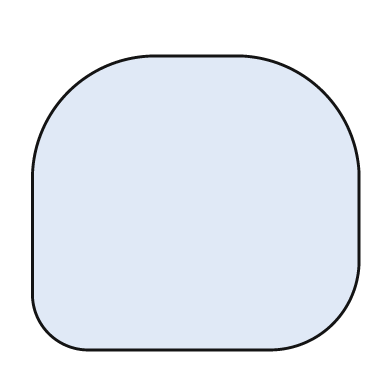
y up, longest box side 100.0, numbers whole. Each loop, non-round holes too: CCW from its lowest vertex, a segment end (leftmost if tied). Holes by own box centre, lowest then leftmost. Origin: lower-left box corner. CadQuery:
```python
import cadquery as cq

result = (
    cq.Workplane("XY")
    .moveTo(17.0, 0.0)
    .lineTo(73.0, 0.0)
    .threePointArc((92.0, 8.0), (100.0, 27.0))
    .lineTo(100.0, 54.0)
    .threePointArc((89.0, 79.0), (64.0, 90.0))
    .lineTo(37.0, 90.0)
    .threePointArc((11.0, 79.0), (0.0, 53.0))
    .lineTo(0.0, 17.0)
    .threePointArc((5.0, 5.0), (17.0, 0.0))
    .close()
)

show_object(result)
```